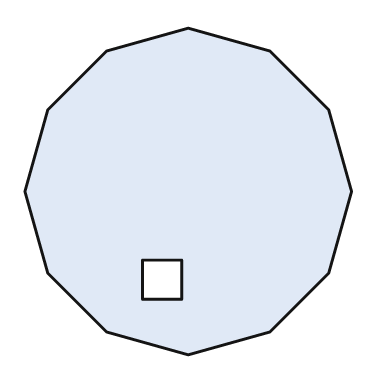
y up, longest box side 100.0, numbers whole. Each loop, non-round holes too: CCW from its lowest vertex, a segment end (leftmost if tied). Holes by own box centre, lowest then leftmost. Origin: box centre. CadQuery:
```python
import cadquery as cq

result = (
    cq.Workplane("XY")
    .moveTo(0.0, -50.0)
    .lineTo(25.0, -43.0)
    .lineTo(43.0, -25.0)
    .lineTo(50.0, 0.0)
    .lineTo(43.0, 25.0)
    .lineTo(25.0, 43.0)
    .lineTo(0.0, 50.0)
    .lineTo(-25.0, 43.0)
    .lineTo(-43.0, 25.0)
    .lineTo(-50.0, 0.0)
    .lineTo(-43.0, -25.0)
    .lineTo(-25.0, -43.0)
    .close()
    .moveTo(-14.0, -33.0)
    .lineTo(-2.0, -33.0)
    .lineTo(-2.0, -21.0)
    .lineTo(-14.0, -21.0)
    .close()
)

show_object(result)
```